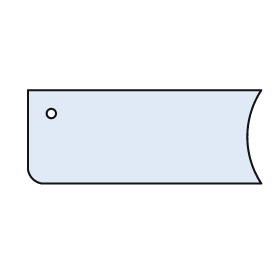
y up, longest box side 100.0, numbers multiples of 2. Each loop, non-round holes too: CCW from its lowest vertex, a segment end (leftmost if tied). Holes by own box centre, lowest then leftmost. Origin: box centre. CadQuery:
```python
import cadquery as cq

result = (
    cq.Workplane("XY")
    .moveTo(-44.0, -20.0)
    .lineTo(50.0, -20.0)
    .threePointArc((44.0, 0.0), (50.0, 20.0))
    .lineTo(-50.0, 20.0)
    .lineTo(-50.0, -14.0)
    .threePointArc((-48.0, -18.0), (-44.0, -20.0))
    .close()
    .moveTo(-40.0, 10.0)
    .circle(2.0)
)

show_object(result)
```